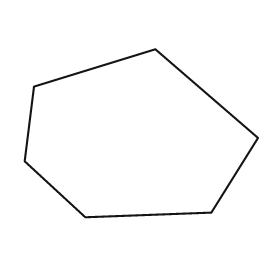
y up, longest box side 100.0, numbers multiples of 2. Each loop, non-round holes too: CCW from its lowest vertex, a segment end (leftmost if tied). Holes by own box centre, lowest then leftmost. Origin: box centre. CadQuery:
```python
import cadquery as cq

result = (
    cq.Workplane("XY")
    .moveTo(-24.0, -36.0)
    .lineTo(30.0, -34.0)
    .lineTo(50.0, -2.0)
    .lineTo(6.0, 36.0)
    .lineTo(-46.0, 20.0)
    .lineTo(-50.0, -12.0)
    .close()
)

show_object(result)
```